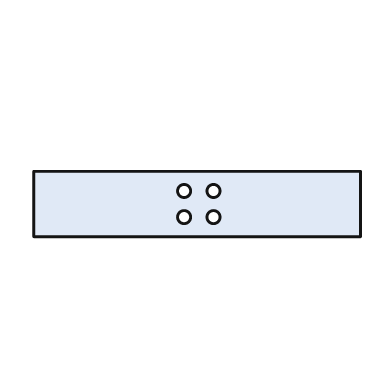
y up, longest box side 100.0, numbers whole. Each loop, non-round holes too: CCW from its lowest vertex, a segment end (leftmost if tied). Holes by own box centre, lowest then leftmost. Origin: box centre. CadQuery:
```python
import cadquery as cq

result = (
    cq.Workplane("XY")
    .moveTo(-50.0, -10.0)
    .lineTo(50.0, -10.0)
    .lineTo(50.0, 10.0)
    .lineTo(-50.0, 10.0)
    .close()
    .moveTo(-4.0, -4.0)
    .circle(2.0)
    .moveTo(5.0, -4.0)
    .circle(2.0)
    .moveTo(-4.0, 4.0)
    .circle(2.0)
    .moveTo(5.0, 4.0)
    .circle(2.0)
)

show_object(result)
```